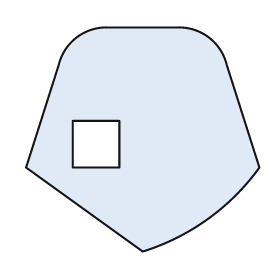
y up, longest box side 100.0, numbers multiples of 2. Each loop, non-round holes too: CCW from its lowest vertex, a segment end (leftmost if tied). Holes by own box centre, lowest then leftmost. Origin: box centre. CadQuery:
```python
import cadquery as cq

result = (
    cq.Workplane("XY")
    .moveTo(0.0, -48.0)
    .threePointArc((28.0, -34.0), (50.0, -12.0))
    .lineTo(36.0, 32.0)
    .threePointArc((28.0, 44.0), (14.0, 48.0))
    .lineTo(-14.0, 48.0)
    .threePointArc((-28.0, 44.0), (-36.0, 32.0))
    .lineTo(-50.0, -12.0)
    .close()
    .moveTo(-30.0, -12.0)
    .lineTo(-10.0, -12.0)
    .lineTo(-10.0, 8.0)
    .lineTo(-30.0, 8.0)
    .close()
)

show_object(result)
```